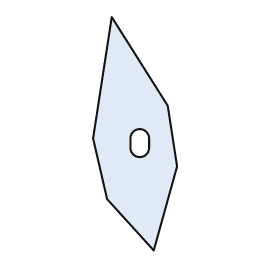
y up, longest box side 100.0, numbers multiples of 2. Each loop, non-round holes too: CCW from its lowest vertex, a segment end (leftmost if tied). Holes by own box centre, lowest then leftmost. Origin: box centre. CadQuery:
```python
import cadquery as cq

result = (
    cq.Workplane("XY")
    .moveTo(8.0, -50.0)
    .lineTo(18.0, -14.0)
    .lineTo(14.0, 12.0)
    .lineTo(-10.0, 50.0)
    .lineTo(-18.0, -2.0)
    .lineTo(-12.0, -28.0)
    .close()
    .moveTo(-2.0, -6.0)
    .threePointArc((2.0, -10.0), (6.0, -6.0))
    .lineTo(6.0, -2.0)
    .threePointArc((2.0, 2.0), (-2.0, -2.0))
    .close()
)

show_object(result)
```